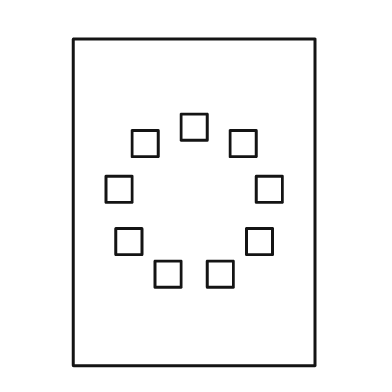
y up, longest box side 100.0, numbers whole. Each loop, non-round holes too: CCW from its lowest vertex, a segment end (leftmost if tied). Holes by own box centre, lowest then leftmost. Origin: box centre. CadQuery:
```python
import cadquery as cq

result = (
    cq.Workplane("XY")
    .moveTo(-37.0, -50.0)
    .lineTo(37.0, -50.0)
    .lineTo(37.0, 50.0)
    .lineTo(-37.0, 50.0)
    .close()
    .moveTo(-12.0, -26.0)
    .lineTo(-4.0, -26.0)
    .lineTo(-4.0, -18.0)
    .lineTo(-12.0, -18.0)
    .close()
    .moveTo(4.0, -26.0)
    .lineTo(12.0, -26.0)
    .lineTo(12.0, -18.0)
    .lineTo(4.0, -18.0)
    .close()
    .moveTo(-24.0, -16.0)
    .lineTo(-16.0, -16.0)
    .lineTo(-16.0, -8.0)
    .lineTo(-24.0, -8.0)
    .close()
    .moveTo(16.0, -16.0)
    .lineTo(24.0, -16.0)
    .lineTo(24.0, -8.0)
    .lineTo(16.0, -8.0)
    .close()
    .moveTo(-27.0, 0.0)
    .lineTo(-19.0, 0.0)
    .lineTo(-19.0, 8.0)
    .lineTo(-27.0, 8.0)
    .close()
    .moveTo(19.0, 0.0)
    .lineTo(27.0, 0.0)
    .lineTo(27.0, 8.0)
    .lineTo(19.0, 8.0)
    .close()
    .moveTo(-19.0, 14.0)
    .lineTo(-11.0, 14.0)
    .lineTo(-11.0, 22.0)
    .lineTo(-19.0, 22.0)
    .close()
    .moveTo(11.0, 14.0)
    .lineTo(19.0, 14.0)
    .lineTo(19.0, 22.0)
    .lineTo(11.0, 22.0)
    .close()
    .moveTo(-4.0, 19.0)
    .lineTo(4.0, 19.0)
    .lineTo(4.0, 27.0)
    .lineTo(-4.0, 27.0)
    .close()
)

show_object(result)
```